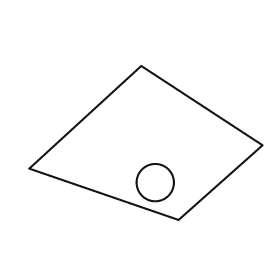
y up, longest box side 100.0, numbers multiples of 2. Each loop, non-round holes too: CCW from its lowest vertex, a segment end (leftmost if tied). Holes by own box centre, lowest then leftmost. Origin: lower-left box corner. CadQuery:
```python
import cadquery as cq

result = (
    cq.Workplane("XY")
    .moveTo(64.0, 0.0)
    .lineTo(100.0, 32.0)
    .lineTo(48.0, 66.0)
    .lineTo(0.0, 22.0)
    .close()
    .moveTo(54.0, 16.0)
    .circle(8.0)
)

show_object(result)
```